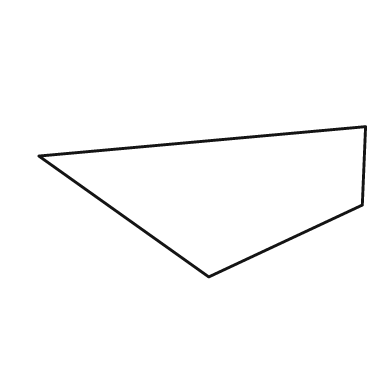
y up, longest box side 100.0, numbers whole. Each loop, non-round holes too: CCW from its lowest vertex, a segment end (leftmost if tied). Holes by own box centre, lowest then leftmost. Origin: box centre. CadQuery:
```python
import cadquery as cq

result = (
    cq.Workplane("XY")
    .moveTo(2.0, -23.0)
    .lineTo(49.0, -1.0)
    .lineTo(50.0, 23.0)
    .lineTo(-50.0, 14.0)
    .close()
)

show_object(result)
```